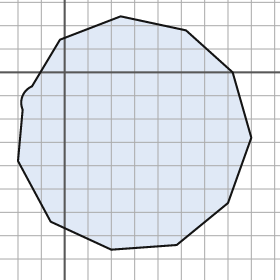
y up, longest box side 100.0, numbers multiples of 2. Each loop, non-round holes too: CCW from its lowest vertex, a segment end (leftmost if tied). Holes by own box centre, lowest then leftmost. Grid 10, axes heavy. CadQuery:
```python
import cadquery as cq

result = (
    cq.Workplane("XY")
    .moveTo(20.0, -76.0)
    .lineTo(48.0, -74.0)
    .lineTo(70.0, -56.0)
    .lineTo(80.0, -28.0)
    .lineTo(72.0, 0.0)
    .lineTo(52.0, 18.0)
    .lineTo(24.0, 24.0)
    .lineTo(-2.0, 14.0)
    .lineTo(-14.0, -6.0)
    .threePointArc((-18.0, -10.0), (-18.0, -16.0))
    .lineTo(-20.0, -38.0)
    .lineTo(-6.0, -64.0)
    .close()
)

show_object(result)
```